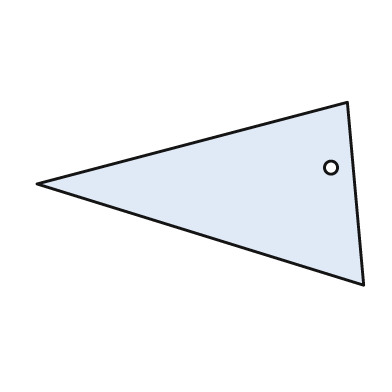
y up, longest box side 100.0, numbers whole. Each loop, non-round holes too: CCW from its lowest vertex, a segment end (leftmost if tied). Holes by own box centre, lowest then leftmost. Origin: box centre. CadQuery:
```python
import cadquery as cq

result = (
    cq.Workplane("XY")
    .moveTo(50.0, -28.0)
    .lineTo(45.0, 28.0)
    .lineTo(-50.0, 3.0)
    .close()
    .moveTo(40.0, 8.0)
    .circle(2.0)
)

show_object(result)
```